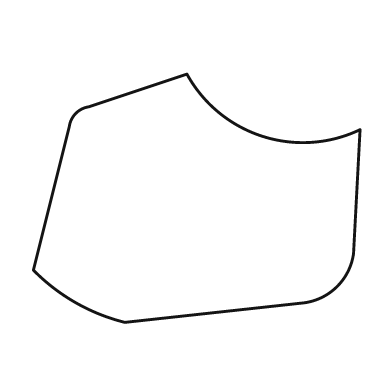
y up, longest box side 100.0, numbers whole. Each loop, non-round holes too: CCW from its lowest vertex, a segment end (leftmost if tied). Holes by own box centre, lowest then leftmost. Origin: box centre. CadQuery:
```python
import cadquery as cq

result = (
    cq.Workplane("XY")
    .moveTo(-22.0, -38.0)
    .lineTo(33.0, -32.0)
    .threePointArc((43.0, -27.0), (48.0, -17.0))
    .lineTo(50.0, 21.0)
    .threePointArc((20.0, 19.0), (-3.0, 38.0))
    .lineTo(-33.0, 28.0)
    .threePointArc((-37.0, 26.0), (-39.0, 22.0))
    .lineTo(-50.0, -22.0)
    .threePointArc((-37.0, -32.0), (-22.0, -38.0))
    .close()
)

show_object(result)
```